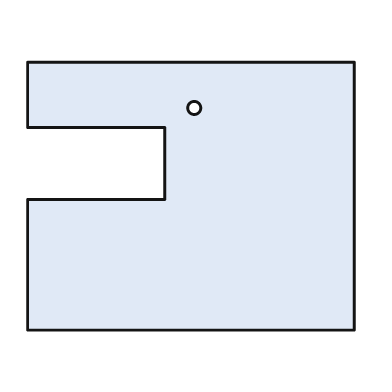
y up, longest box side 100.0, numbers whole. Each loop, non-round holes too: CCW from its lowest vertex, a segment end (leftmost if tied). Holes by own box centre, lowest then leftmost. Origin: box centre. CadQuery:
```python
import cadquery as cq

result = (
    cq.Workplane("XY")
    .moveTo(-50.0, -41.0)
    .lineTo(50.0, -41.0)
    .lineTo(50.0, 41.0)
    .lineTo(-50.0, 41.0)
    .lineTo(-50.0, 21.0)
    .lineTo(-8.0, 21.0)
    .lineTo(-8.0, -1.0)
    .lineTo(-50.0, -1.0)
    .close()
    .moveTo(1.0, 27.0)
    .circle(2.0)
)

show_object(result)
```